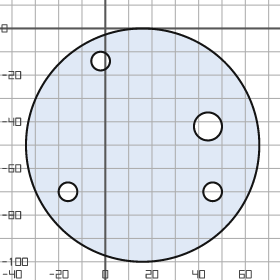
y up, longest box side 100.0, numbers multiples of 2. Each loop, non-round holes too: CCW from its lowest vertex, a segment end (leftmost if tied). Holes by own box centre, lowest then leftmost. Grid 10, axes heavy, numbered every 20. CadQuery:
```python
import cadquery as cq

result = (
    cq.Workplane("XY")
    .moveTo(16.0, -50.0)
    .circle(50.0)
    .moveTo(-16.0, -70.0)
    .circle(4.0)
    .moveTo(46.0, -70.0)
    .circle(4.0)
    .moveTo(44.0, -42.0)
    .circle(6.0)
    .moveTo(-2.0, -14.0)
    .circle(4.0)
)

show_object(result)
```